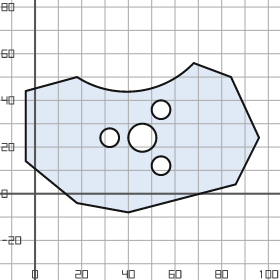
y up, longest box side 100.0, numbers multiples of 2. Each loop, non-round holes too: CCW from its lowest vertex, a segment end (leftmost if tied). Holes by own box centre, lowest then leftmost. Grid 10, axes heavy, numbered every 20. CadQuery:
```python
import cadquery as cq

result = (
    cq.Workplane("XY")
    .moveTo(40.0, -8.0)
    .lineTo(86.0, 4.0)
    .lineTo(96.0, 24.0)
    .lineTo(84.0, 50.0)
    .lineTo(68.0, 56.0)
    .threePointArc((44.0, 44.0), (18.0, 50.0))
    .lineTo(-4.0, 44.0)
    .lineTo(-4.0, 14.0)
    .lineTo(18.0, -4.0)
    .close()
    .moveTo(54.0, 12.0)
    .circle(4.0)
    .moveTo(32.0, 24.0)
    .circle(4.0)
    .moveTo(46.0, 24.0)
    .circle(6.0)
    .moveTo(54.0, 36.0)
    .circle(4.0)
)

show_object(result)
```